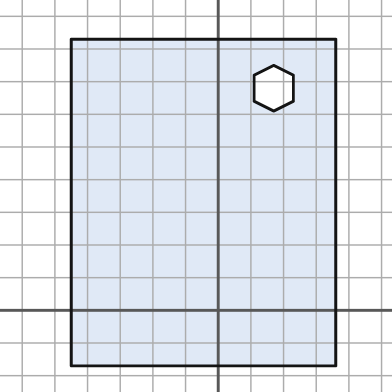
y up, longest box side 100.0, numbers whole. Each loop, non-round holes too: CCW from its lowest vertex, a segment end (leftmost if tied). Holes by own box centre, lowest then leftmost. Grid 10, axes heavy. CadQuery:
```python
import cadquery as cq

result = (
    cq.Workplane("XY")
    .moveTo(-45.0, -17.0)
    .lineTo(36.0, -17.0)
    .lineTo(36.0, 83.0)
    .lineTo(-45.0, 83.0)
    .close()
    .moveTo(17.0, 61.0)
    .lineTo(23.0, 64.0)
    .lineTo(23.0, 72.0)
    .lineTo(17.0, 75.0)
    .lineTo(11.0, 72.0)
    .lineTo(11.0, 64.0)
    .close()
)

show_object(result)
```